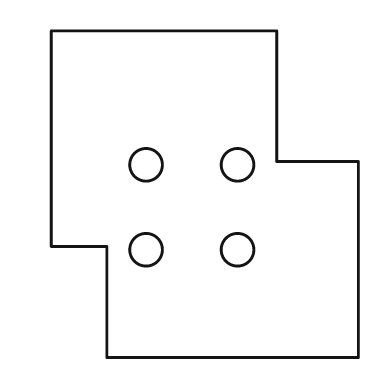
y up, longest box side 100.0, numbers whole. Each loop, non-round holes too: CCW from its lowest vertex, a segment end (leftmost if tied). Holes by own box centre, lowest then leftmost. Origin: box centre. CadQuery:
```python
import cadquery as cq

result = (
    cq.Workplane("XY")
    .moveTo(-30.0, -50.0)
    .lineTo(47.0, -50.0)
    .lineTo(47.0, 10.0)
    .lineTo(22.0, 10.0)
    .lineTo(22.0, 50.0)
    .lineTo(-47.0, 50.0)
    .lineTo(-47.0, -16.0)
    .lineTo(-30.0, -16.0)
    .close()
    .moveTo(-18.0, -17.0)
    .circle(5.0)
    .moveTo(10.0, -17.0)
    .circle(5.0)
    .moveTo(-18.0, 9.0)
    .circle(5.0)
    .moveTo(10.0, 9.0)
    .circle(5.0)
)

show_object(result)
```